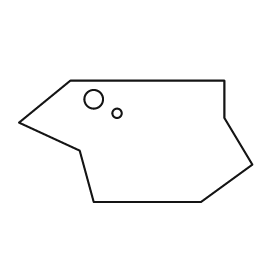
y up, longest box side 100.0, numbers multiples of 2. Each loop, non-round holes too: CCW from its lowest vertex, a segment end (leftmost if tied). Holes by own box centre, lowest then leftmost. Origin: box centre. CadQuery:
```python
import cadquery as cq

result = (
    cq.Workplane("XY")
    .moveTo(-18.0, -26.0)
    .lineTo(28.0, -26.0)
    .lineTo(50.0, -10.0)
    .lineTo(38.0, 10.0)
    .lineTo(38.0, 26.0)
    .lineTo(-28.0, 26.0)
    .lineTo(-50.0, 8.0)
    .lineTo(-24.0, -4.0)
    .close()
    .moveTo(-8.0, 12.0)
    .circle(2.0)
    .moveTo(-18.0, 18.0)
    .circle(4.0)
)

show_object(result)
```